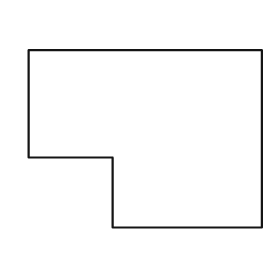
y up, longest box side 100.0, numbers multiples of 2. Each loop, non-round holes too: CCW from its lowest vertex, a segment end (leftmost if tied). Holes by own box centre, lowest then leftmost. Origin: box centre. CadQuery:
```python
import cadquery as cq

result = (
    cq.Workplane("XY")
    .moveTo(-14.0, -38.0)
    .lineTo(50.0, -38.0)
    .lineTo(50.0, 38.0)
    .lineTo(-50.0, 38.0)
    .lineTo(-50.0, -8.0)
    .lineTo(-14.0, -8.0)
    .close()
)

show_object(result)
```